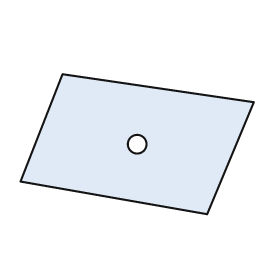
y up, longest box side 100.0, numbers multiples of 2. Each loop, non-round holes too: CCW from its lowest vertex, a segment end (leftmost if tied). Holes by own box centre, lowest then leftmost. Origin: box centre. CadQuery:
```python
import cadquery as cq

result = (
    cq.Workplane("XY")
    .moveTo(30.0, -30.0)
    .lineTo(50.0, 18.0)
    .lineTo(-32.0, 30.0)
    .lineTo(-50.0, -16.0)
    .close()
    .moveTo(0.0, 0.0)
    .circle(4.0)
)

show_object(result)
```